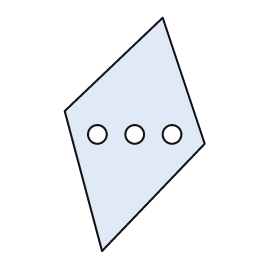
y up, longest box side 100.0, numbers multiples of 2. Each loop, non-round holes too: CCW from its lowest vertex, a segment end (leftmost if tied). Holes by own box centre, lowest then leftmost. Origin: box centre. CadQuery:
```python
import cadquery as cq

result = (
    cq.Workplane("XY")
    .moveTo(-14.0, -50.0)
    .lineTo(30.0, -4.0)
    .lineTo(12.0, 50.0)
    .lineTo(-30.0, 10.0)
    .close()
    .moveTo(-16.0, 0.0)
    .circle(4.0)
    .moveTo(0.0, 0.0)
    .circle(4.0)
    .moveTo(16.0, 0.0)
    .circle(4.0)
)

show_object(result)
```